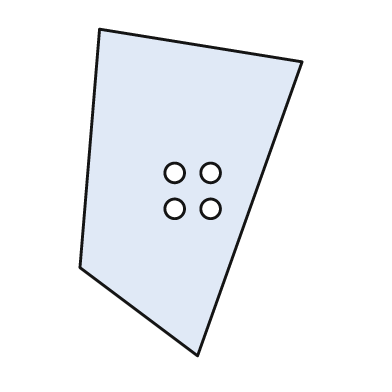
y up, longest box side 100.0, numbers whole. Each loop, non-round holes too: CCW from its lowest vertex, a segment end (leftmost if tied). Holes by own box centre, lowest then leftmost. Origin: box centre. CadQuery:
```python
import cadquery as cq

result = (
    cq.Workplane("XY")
    .moveTo(2.0, -50.0)
    .lineTo(34.0, 40.0)
    .lineTo(-28.0, 50.0)
    .lineTo(-34.0, -23.0)
    .close()
    .moveTo(-5.0, -5.0)
    .circle(3.0)
    .moveTo(6.0, -5.0)
    .circle(3.0)
    .moveTo(-5.0, 6.0)
    .circle(3.0)
    .moveTo(6.0, 6.0)
    .circle(3.0)
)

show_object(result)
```